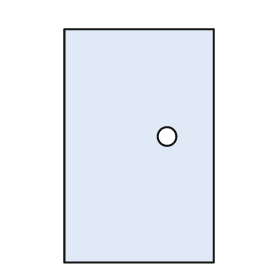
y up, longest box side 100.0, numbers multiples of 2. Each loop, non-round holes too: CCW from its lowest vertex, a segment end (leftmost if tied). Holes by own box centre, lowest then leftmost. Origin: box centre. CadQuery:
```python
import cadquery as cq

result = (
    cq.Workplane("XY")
    .moveTo(-32.0, -50.0)
    .lineTo(32.0, -50.0)
    .lineTo(32.0, 50.0)
    .lineTo(-32.0, 50.0)
    .close()
    .moveTo(12.0, 4.0)
    .circle(4.0)
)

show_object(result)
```